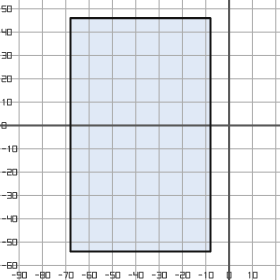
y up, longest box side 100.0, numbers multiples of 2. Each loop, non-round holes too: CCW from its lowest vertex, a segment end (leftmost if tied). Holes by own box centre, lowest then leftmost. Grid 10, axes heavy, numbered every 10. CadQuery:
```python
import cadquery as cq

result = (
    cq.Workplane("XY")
    .moveTo(-68.0, -54.0)
    .lineTo(-8.0, -54.0)
    .lineTo(-8.0, 46.0)
    .lineTo(-68.0, 46.0)
    .close()
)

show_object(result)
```